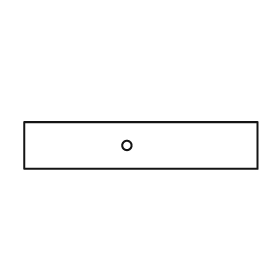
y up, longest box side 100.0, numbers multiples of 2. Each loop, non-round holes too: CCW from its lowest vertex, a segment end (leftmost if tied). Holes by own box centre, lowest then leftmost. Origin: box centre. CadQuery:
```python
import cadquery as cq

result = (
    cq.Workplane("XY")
    .moveTo(-50.0, -10.0)
    .lineTo(50.0, -10.0)
    .lineTo(50.0, 10.0)
    .lineTo(-50.0, 10.0)
    .close()
    .moveTo(-6.0, 0.0)
    .circle(2.0)
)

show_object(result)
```